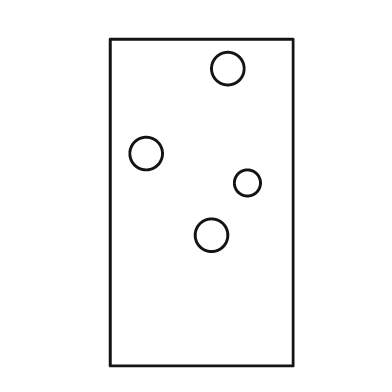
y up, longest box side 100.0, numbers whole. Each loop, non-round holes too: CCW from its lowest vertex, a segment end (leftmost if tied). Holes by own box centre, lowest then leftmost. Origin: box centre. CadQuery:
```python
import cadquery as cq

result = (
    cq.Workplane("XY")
    .moveTo(-28.0, -50.0)
    .lineTo(28.0, -50.0)
    .lineTo(28.0, 50.0)
    .lineTo(-28.0, 50.0)
    .close()
    .moveTo(3.0, -10.0)
    .circle(5.0)
    .moveTo(14.0, 6.0)
    .circle(4.0)
    .moveTo(-17.0, 15.0)
    .circle(5.0)
    .moveTo(8.0, 41.0)
    .circle(5.0)
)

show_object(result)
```